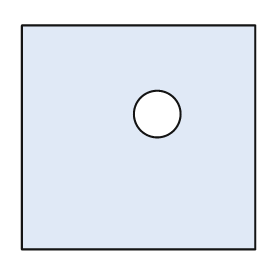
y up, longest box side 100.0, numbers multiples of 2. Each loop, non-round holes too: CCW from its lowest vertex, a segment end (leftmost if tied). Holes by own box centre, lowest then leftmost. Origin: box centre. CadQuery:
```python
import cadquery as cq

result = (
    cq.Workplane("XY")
    .moveTo(-50.0, -48.0)
    .lineTo(50.0, -48.0)
    .lineTo(50.0, 48.0)
    .lineTo(-50.0, 48.0)
    .close()
    .moveTo(8.0, 10.0)
    .circle(10.0)
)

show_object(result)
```